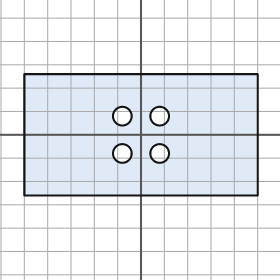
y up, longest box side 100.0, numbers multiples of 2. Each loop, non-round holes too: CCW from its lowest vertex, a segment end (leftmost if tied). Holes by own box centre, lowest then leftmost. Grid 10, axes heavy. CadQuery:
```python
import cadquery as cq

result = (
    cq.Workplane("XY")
    .moveTo(-50.0, -26.0)
    .lineTo(50.0, -26.0)
    .lineTo(50.0, 26.0)
    .lineTo(-50.0, 26.0)
    .close()
    .moveTo(-8.0, -8.0)
    .circle(4.0)
    .moveTo(8.0, -8.0)
    .circle(4.0)
    .moveTo(-8.0, 8.0)
    .circle(4.0)
    .moveTo(8.0, 8.0)
    .circle(4.0)
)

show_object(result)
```